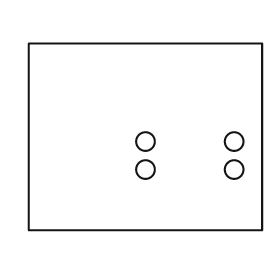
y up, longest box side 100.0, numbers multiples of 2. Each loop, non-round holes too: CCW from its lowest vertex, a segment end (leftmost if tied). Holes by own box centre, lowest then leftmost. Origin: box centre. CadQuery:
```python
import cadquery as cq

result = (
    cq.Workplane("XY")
    .moveTo(-50.0, -40.0)
    .lineTo(50.0, -40.0)
    .lineTo(50.0, 40.0)
    .lineTo(-50.0, 40.0)
    .close()
    .moveTo(0.0, -14.0)
    .circle(4.0)
    .moveTo(38.0, -14.0)
    .circle(4.0)
    .moveTo(0.0, -2.0)
    .circle(4.0)
    .moveTo(38.0, -2.0)
    .circle(4.0)
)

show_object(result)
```